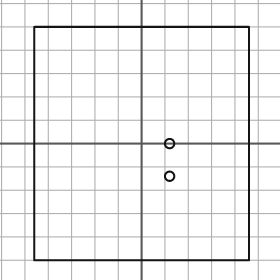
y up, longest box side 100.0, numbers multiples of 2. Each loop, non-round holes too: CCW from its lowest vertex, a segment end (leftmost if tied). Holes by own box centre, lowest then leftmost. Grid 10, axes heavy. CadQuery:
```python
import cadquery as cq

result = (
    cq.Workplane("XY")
    .moveTo(-46.0, -50.0)
    .lineTo(46.0, -50.0)
    .lineTo(46.0, 50.0)
    .lineTo(-46.0, 50.0)
    .close()
    .moveTo(12.0, -14.0)
    .circle(2.0)
    .moveTo(12.0, 0.0)
    .circle(2.0)
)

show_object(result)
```